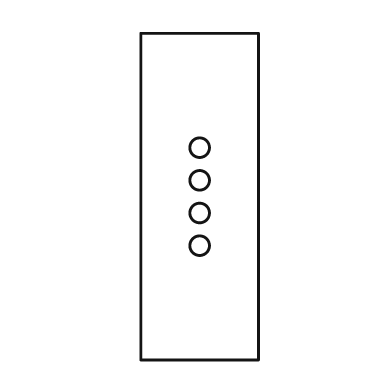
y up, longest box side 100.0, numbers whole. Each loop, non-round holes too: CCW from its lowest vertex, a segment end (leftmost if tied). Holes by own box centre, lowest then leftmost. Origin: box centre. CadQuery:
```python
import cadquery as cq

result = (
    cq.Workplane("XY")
    .moveTo(-18.0, -50.0)
    .lineTo(18.0, -50.0)
    .lineTo(18.0, 50.0)
    .lineTo(-18.0, 50.0)
    .close()
    .moveTo(0.0, -15.0)
    .circle(3.0)
    .moveTo(0.0, -5.0)
    .circle(3.0)
    .moveTo(0.0, 5.0)
    .circle(3.0)
    .moveTo(0.0, 15.0)
    .circle(3.0)
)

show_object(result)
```